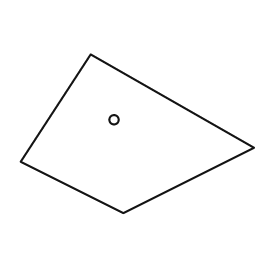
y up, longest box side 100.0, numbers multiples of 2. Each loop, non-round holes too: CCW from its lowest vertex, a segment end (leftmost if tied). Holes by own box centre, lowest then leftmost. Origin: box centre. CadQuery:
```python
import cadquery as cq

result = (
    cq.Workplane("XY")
    .moveTo(-6.0, -34.0)
    .lineTo(50.0, -6.0)
    .lineTo(-20.0, 34.0)
    .lineTo(-50.0, -12.0)
    .close()
    .moveTo(-10.0, 6.0)
    .circle(2.0)
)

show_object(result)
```